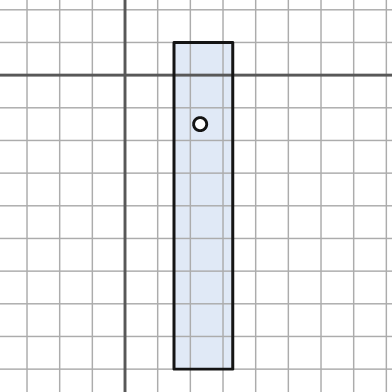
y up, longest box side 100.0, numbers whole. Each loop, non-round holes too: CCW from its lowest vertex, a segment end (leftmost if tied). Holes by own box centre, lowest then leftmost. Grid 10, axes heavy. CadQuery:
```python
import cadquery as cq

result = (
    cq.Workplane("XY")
    .moveTo(15.0, -90.0)
    .lineTo(33.0, -90.0)
    .lineTo(33.0, 10.0)
    .lineTo(15.0, 10.0)
    .close()
    .moveTo(23.0, -15.0)
    .circle(2.0)
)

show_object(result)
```